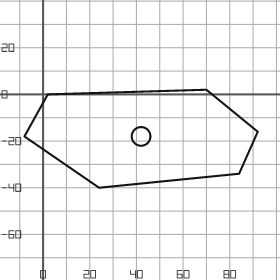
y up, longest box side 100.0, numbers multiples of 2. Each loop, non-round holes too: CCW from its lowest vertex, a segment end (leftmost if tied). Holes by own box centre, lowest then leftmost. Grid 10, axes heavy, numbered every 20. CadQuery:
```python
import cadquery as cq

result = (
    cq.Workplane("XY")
    .moveTo(24.0, -40.0)
    .lineTo(84.0, -34.0)
    .lineTo(92.0, -16.0)
    .lineTo(70.0, 2.0)
    .lineTo(2.0, 0.0)
    .lineTo(-8.0, -18.0)
    .close()
    .moveTo(42.0, -18.0)
    .circle(4.0)
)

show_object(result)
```